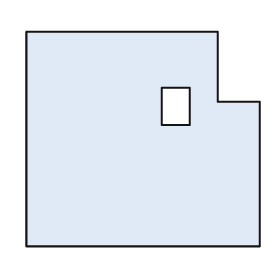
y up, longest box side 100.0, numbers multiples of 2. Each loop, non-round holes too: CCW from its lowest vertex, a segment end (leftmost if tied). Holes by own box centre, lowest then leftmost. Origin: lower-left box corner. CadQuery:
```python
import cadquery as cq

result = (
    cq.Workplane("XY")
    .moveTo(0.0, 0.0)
    .lineTo(100.0, 0.0)
    .lineTo(100.0, 62.0)
    .lineTo(82.0, 62.0)
    .lineTo(82.0, 92.0)
    .lineTo(0.0, 92.0)
    .close()
    .moveTo(58.0, 52.0)
    .lineTo(70.0, 52.0)
    .lineTo(70.0, 68.0)
    .lineTo(58.0, 68.0)
    .close()
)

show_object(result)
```